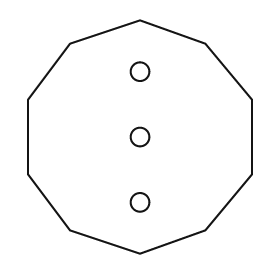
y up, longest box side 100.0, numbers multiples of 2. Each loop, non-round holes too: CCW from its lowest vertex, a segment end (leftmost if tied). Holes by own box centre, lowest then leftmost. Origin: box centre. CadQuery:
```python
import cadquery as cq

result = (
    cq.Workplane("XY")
    .moveTo(0.0, -50.0)
    .lineTo(28.0, -40.0)
    .lineTo(48.0, -16.0)
    .lineTo(48.0, 16.0)
    .lineTo(28.0, 40.0)
    .lineTo(0.0, 50.0)
    .lineTo(-30.0, 40.0)
    .lineTo(-48.0, 16.0)
    .lineTo(-48.0, -16.0)
    .lineTo(-30.0, -40.0)
    .close()
    .moveTo(0.0, -28.0)
    .circle(4.0)
    .moveTo(0.0, 0.0)
    .circle(4.0)
    .moveTo(0.0, 28.0)
    .circle(4.0)
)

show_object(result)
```